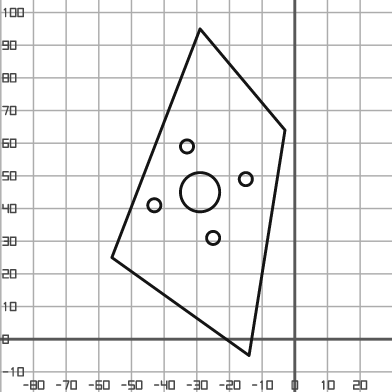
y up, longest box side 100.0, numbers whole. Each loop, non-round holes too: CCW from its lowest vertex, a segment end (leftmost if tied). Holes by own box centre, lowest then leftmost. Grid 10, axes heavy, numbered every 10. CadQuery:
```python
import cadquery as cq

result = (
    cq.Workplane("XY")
    .moveTo(-14.0, -5.0)
    .lineTo(-3.0, 64.0)
    .lineTo(-29.0, 95.0)
    .lineTo(-56.0, 25.0)
    .close()
    .moveTo(-25.0, 31.0)
    .circle(2.0)
    .moveTo(-43.0, 41.0)
    .circle(2.0)
    .moveTo(-29.0, 45.0)
    .circle(6.0)
    .moveTo(-15.0, 49.0)
    .circle(2.0)
    .moveTo(-33.0, 59.0)
    .circle(2.0)
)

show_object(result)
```